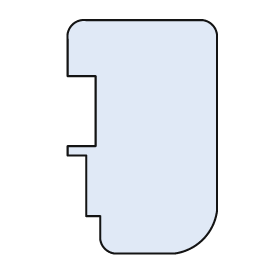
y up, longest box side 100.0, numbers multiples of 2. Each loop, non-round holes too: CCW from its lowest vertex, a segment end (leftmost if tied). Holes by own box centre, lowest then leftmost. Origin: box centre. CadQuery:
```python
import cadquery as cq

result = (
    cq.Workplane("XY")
    .moveTo(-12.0, -50.0)
    .lineTo(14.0, -50.0)
    .threePointArc((26.0, -44.0), (32.0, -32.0))
    .lineTo(32.0, 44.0)
    .threePointArc((30.0, 48.0), (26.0, 50.0))
    .lineTo(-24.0, 50.0)
    .threePointArc((-30.0, 48.0), (-32.0, 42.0))
    .lineTo(-32.0, 26.0)
    .lineTo(-20.0, 26.0)
    .lineTo(-20.0, -4.0)
    .lineTo(-32.0, -4.0)
    .lineTo(-32.0, -8.0)
    .lineTo(-24.0, -8.0)
    .lineTo(-24.0, -34.0)
    .lineTo(-18.0, -34.0)
    .lineTo(-18.0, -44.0)
    .threePointArc((-16.0, -48.0), (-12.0, -50.0))
    .close()
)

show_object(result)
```